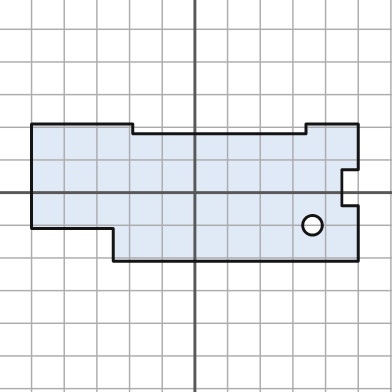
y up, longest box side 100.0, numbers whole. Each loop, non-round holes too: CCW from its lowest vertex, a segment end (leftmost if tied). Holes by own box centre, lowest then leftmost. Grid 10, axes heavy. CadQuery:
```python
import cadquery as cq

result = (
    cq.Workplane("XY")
    .moveTo(-25.0, -21.0)
    .lineTo(50.0, -21.0)
    .lineTo(50.0, -4.0)
    .lineTo(45.0, -4.0)
    .lineTo(45.0, 7.0)
    .lineTo(50.0, 7.0)
    .lineTo(50.0, 21.0)
    .lineTo(34.0, 21.0)
    .lineTo(34.0, 18.0)
    .lineTo(-19.0, 18.0)
    .lineTo(-19.0, 21.0)
    .lineTo(-50.0, 21.0)
    .lineTo(-50.0, -11.0)
    .lineTo(-25.0, -11.0)
    .close()
    .moveTo(36.0, -10.0)
    .circle(3.0)
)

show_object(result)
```